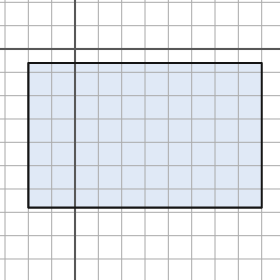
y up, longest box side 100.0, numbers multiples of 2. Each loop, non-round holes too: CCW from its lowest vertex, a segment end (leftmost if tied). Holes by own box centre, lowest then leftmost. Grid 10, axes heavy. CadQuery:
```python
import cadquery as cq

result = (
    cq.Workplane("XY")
    .moveTo(-20.0, -68.0)
    .lineTo(80.0, -68.0)
    .lineTo(80.0, -6.0)
    .lineTo(-20.0, -6.0)
    .close()
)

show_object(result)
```